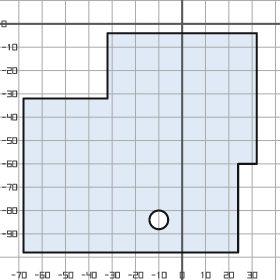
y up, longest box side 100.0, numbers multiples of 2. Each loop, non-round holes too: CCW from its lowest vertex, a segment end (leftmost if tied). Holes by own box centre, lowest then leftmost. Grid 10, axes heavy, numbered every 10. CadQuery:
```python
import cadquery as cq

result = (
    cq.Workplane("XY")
    .moveTo(-68.0, -98.0)
    .lineTo(24.0, -98.0)
    .lineTo(24.0, -60.0)
    .lineTo(32.0, -60.0)
    .lineTo(32.0, -4.0)
    .lineTo(-32.0, -4.0)
    .lineTo(-32.0, -32.0)
    .lineTo(-68.0, -32.0)
    .close()
    .moveTo(-10.0, -84.0)
    .circle(4.0)
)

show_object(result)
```